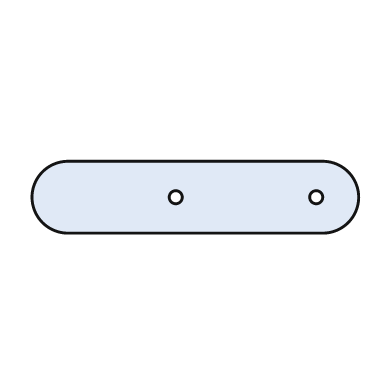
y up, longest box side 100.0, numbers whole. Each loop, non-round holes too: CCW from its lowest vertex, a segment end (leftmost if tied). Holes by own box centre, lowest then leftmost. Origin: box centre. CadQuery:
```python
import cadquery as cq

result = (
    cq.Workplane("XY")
    .moveTo(-39.0, -11.0)
    .lineTo(39.0, -11.0)
    .threePointArc((50.0, 0.0), (39.0, 11.0))
    .lineTo(-39.0, 11.0)
    .threePointArc((-50.0, 0.0), (-39.0, -11.0))
    .close()
    .moveTo(-6.0, 0.0)
    .circle(2.0)
    .moveTo(37.0, 0.0)
    .circle(2.0)
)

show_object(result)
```